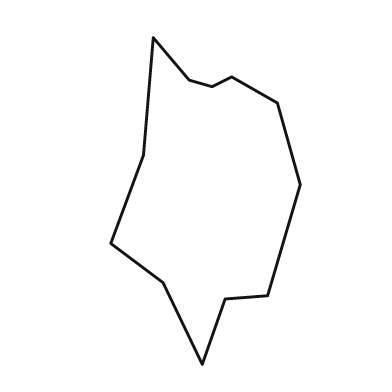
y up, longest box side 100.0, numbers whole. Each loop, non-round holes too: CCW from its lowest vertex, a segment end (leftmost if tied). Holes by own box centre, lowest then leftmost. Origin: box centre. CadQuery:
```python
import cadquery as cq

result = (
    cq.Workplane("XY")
    .moveTo(-1.0, -50.0)
    .lineTo(6.0, -30.0)
    .lineTo(19.0, -29.0)
    .lineTo(29.0, 5.0)
    .lineTo(22.0, 30.0)
    .lineTo(8.0, 38.0)
    .lineTo(2.0, 35.0)
    .lineTo(-5.0, 37.0)
    .lineTo(-16.0, 50.0)
    .lineTo(-19.0, 14.0)
    .lineTo(-29.0, -13.0)
    .lineTo(-13.0, -25.0)
    .close()
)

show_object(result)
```